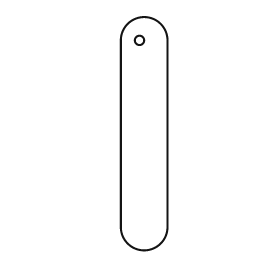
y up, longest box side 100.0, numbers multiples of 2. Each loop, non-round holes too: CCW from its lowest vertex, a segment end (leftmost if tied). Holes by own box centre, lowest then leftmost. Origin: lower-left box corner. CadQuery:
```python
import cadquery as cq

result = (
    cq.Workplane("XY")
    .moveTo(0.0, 10.0)
    .threePointArc((10.0, 0.0), (20.0, 10.0))
    .lineTo(20.0, 90.0)
    .threePointArc((10.0, 100.0), (0.0, 90.0))
    .close()
    .moveTo(8.0, 90.0)
    .circle(2.0)
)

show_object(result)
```